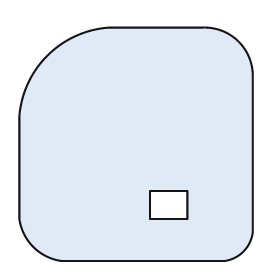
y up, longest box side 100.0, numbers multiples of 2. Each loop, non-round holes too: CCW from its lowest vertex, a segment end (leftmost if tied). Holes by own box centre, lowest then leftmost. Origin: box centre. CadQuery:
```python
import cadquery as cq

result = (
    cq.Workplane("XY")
    .moveTo(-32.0, -50.0)
    .lineTo(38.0, -50.0)
    .threePointArc((46.0, -46.0), (50.0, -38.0))
    .lineTo(50.0, 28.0)
    .threePointArc((44.0, 44.0), (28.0, 50.0))
    .lineTo(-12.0, 50.0)
    .threePointArc((-38.0, 38.0), (-50.0, 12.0))
    .lineTo(-50.0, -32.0)
    .threePointArc((-44.0, -44.0), (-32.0, -50.0))
    .close()
    .moveTo(6.0, -32.0)
    .lineTo(22.0, -32.0)
    .lineTo(22.0, -20.0)
    .lineTo(6.0, -20.0)
    .close()
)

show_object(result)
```